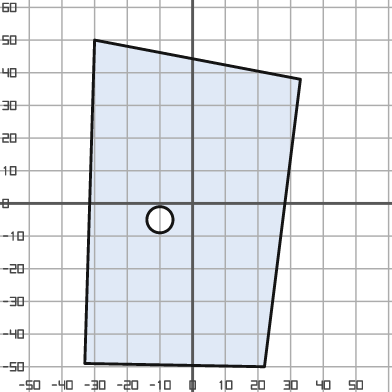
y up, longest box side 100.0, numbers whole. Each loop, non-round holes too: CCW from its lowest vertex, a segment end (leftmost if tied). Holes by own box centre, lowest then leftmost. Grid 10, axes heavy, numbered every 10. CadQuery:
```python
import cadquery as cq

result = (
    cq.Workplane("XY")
    .moveTo(22.0, -50.0)
    .lineTo(33.0, 38.0)
    .lineTo(-30.0, 50.0)
    .lineTo(-33.0, -49.0)
    .close()
    .moveTo(-10.0, -5.0)
    .circle(4.0)
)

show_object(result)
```